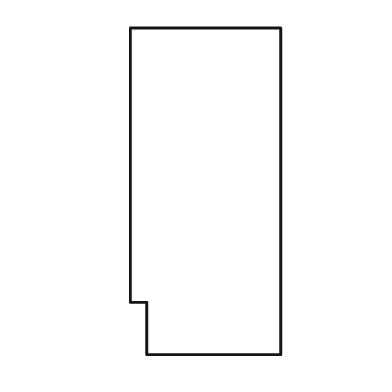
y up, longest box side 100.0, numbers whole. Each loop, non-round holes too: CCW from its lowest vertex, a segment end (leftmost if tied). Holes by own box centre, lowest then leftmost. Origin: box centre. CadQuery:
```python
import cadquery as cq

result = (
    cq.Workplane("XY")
    .moveTo(-18.0, -50.0)
    .lineTo(23.0, -50.0)
    .lineTo(23.0, 50.0)
    .lineTo(-23.0, 50.0)
    .lineTo(-23.0, -34.0)
    .lineTo(-18.0, -34.0)
    .close()
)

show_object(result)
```